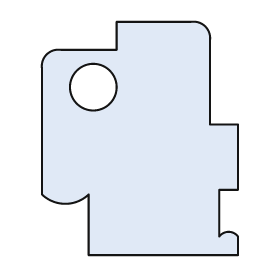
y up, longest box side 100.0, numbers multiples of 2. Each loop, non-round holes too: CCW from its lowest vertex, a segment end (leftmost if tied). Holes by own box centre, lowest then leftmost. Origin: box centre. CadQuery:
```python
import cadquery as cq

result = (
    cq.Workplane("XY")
    .moveTo(-22.0, -50.0)
    .lineTo(42.0, -50.0)
    .lineTo(42.0, -42.0)
    .threePointArc((38.0, -40.0), (34.0, -42.0))
    .lineTo(34.0, -22.0)
    .lineTo(42.0, -22.0)
    .lineTo(42.0, 6.0)
    .lineTo(30.0, 6.0)
    .lineTo(30.0, 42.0)
    .threePointArc((28.0, 48.0), (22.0, 50.0))
    .lineTo(-10.0, 50.0)
    .lineTo(-10.0, 38.0)
    .lineTo(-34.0, 38.0)
    .threePointArc((-40.0, 36.0), (-42.0, 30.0))
    .lineTo(-42.0, -24.0)
    .threePointArc((-32.0, -28.0), (-22.0, -24.0))
    .close()
    .moveTo(-20.0, 22.0)
    .circle(10.0)
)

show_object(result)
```